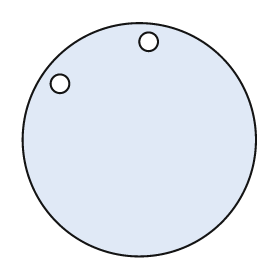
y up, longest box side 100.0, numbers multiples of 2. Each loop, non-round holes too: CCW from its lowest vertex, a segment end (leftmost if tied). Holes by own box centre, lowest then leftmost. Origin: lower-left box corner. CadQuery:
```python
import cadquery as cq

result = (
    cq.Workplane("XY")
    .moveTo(50.0, 50.0)
    .circle(50.0)
    .moveTo(16.0, 74.0)
    .circle(4.0)
    .moveTo(54.0, 92.0)
    .circle(4.0)
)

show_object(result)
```